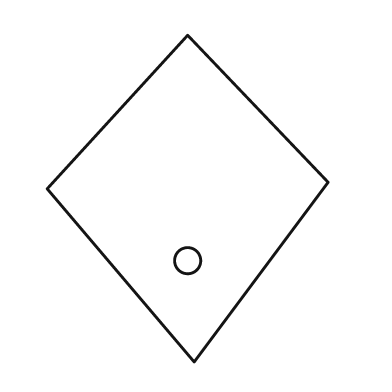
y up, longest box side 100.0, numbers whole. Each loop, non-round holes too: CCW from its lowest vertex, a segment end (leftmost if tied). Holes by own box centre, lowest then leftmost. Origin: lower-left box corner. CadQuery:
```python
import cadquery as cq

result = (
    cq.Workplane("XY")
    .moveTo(45.0, 0.0)
    .lineTo(86.0, 55.0)
    .lineTo(43.0, 100.0)
    .lineTo(0.0, 53.0)
    .close()
    .moveTo(43.0, 31.0)
    .circle(4.0)
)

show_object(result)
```